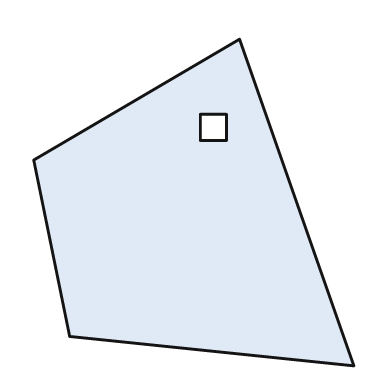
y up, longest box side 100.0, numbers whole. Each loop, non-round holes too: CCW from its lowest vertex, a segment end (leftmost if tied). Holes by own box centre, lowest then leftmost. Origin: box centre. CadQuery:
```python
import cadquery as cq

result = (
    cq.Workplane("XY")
    .moveTo(49.0, -50.0)
    .lineTo(14.0, 50.0)
    .lineTo(-49.0, 13.0)
    .lineTo(-38.0, -41.0)
    .close()
    .moveTo(2.0, 19.0)
    .lineTo(10.0, 19.0)
    .lineTo(10.0, 27.0)
    .lineTo(2.0, 27.0)
    .close()
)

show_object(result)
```